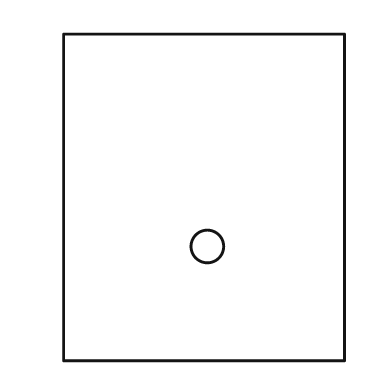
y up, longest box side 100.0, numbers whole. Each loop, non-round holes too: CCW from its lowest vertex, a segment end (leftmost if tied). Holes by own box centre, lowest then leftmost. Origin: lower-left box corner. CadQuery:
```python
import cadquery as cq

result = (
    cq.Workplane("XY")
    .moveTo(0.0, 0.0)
    .lineTo(86.0, 0.0)
    .lineTo(86.0, 100.0)
    .lineTo(0.0, 100.0)
    .close()
    .moveTo(44.0, 35.0)
    .circle(5.0)
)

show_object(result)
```